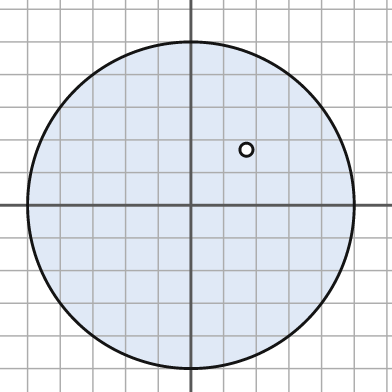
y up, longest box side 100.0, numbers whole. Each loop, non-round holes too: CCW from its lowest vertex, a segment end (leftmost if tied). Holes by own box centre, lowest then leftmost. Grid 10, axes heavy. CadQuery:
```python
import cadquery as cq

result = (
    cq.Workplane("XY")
    .moveTo(0.0, 0.0)
    .circle(50.0)
    .moveTo(17.0, 17.0)
    .circle(2.0)
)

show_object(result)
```